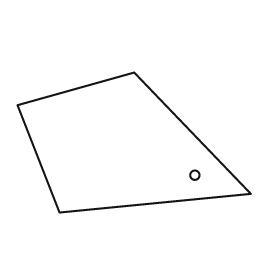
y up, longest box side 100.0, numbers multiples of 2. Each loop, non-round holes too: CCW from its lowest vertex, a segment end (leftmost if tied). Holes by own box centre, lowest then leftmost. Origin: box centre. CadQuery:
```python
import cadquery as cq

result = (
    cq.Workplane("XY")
    .moveTo(-32.0, -30.0)
    .lineTo(50.0, -22.0)
    .lineTo(0.0, 30.0)
    .lineTo(-50.0, 16.0)
    .close()
    .moveTo(26.0, -14.0)
    .circle(2.0)
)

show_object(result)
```